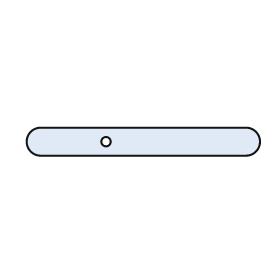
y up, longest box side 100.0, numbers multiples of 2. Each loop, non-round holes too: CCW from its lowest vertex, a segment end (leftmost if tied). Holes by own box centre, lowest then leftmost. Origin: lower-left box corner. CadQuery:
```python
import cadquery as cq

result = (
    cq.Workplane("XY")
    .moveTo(6.0, 0.0)
    .lineTo(94.0, 0.0)
    .threePointArc((100.0, 6.0), (94.0, 12.0))
    .lineTo(6.0, 12.0)
    .threePointArc((0.0, 6.0), (6.0, 0.0))
    .close()
    .moveTo(34.0, 6.0)
    .circle(2.0)
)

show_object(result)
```